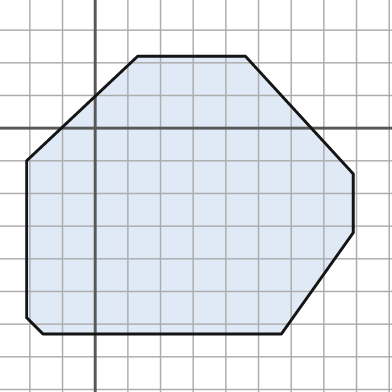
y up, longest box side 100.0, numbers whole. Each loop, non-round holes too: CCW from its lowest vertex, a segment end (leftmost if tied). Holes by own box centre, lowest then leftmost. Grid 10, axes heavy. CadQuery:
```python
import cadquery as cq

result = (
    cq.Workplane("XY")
    .moveTo(-16.0, -63.0)
    .lineTo(57.0, -63.0)
    .lineTo(79.0, -32.0)
    .lineTo(79.0, -14.0)
    .lineTo(46.0, 22.0)
    .lineTo(13.0, 22.0)
    .lineTo(-21.0, -10.0)
    .lineTo(-21.0, -58.0)
    .close()
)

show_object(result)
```